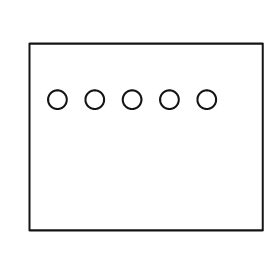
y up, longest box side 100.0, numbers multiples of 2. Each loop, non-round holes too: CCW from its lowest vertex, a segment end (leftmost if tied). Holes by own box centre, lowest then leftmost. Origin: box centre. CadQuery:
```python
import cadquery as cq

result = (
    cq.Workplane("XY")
    .moveTo(-50.0, -40.0)
    .lineTo(50.0, -40.0)
    .lineTo(50.0, 40.0)
    .lineTo(-50.0, 40.0)
    .close()
    .moveTo(-38.0, 16.0)
    .circle(4.0)
    .moveTo(-22.0, 16.0)
    .circle(4.0)
    .moveTo(-6.0, 16.0)
    .circle(4.0)
    .moveTo(10.0, 16.0)
    .circle(4.0)
    .moveTo(26.0, 16.0)
    .circle(4.0)
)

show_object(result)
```